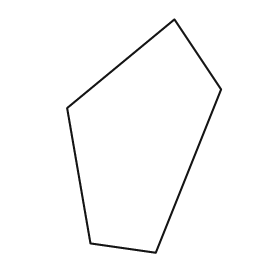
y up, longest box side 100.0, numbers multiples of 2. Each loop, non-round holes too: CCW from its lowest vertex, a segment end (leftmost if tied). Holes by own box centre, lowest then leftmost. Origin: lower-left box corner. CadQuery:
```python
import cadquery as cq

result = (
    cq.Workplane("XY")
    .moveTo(38.0, 0.0)
    .lineTo(66.0, 70.0)
    .lineTo(46.0, 100.0)
    .lineTo(0.0, 62.0)
    .lineTo(10.0, 4.0)
    .close()
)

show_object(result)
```